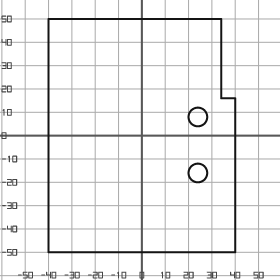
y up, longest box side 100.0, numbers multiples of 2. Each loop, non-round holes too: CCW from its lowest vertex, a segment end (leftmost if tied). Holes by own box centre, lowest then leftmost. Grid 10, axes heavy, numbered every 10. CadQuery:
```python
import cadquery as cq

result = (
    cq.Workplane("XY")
    .moveTo(-40.0, -50.0)
    .lineTo(40.0, -50.0)
    .lineTo(40.0, 16.0)
    .lineTo(34.0, 16.0)
    .lineTo(34.0, 50.0)
    .lineTo(-40.0, 50.0)
    .close()
    .moveTo(24.0, -16.0)
    .circle(4.0)
    .moveTo(24.0, 8.0)
    .circle(4.0)
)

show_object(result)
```